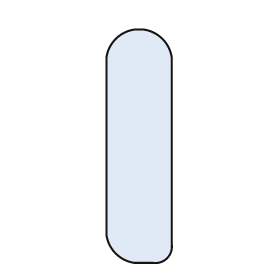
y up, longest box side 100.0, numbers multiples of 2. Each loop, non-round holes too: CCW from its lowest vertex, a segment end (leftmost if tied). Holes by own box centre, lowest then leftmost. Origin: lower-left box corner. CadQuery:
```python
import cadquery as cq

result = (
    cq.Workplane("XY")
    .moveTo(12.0, 0.0)
    .lineTo(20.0, 0.0)
    .threePointArc((26.0, 2.0), (28.0, 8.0))
    .lineTo(28.0, 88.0)
    .threePointArc((24.0, 96.0), (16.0, 100.0))
    .lineTo(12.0, 100.0)
    .threePointArc((4.0, 96.0), (0.0, 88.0))
    .lineTo(0.0, 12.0)
    .threePointArc((4.0, 4.0), (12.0, 0.0))
    .close()
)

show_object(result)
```